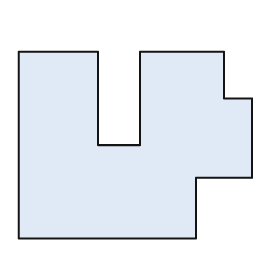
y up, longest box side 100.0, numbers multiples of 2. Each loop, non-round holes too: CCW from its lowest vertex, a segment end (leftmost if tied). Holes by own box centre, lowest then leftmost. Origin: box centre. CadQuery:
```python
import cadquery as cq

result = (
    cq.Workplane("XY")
    .moveTo(-50.0, -40.0)
    .lineTo(26.0, -40.0)
    .lineTo(26.0, -14.0)
    .lineTo(50.0, -14.0)
    .lineTo(50.0, 20.0)
    .lineTo(38.0, 20.0)
    .lineTo(38.0, 40.0)
    .lineTo(2.0, 40.0)
    .lineTo(2.0, 0.0)
    .lineTo(-16.0, 0.0)
    .lineTo(-16.0, 40.0)
    .lineTo(-50.0, 40.0)
    .close()
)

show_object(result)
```